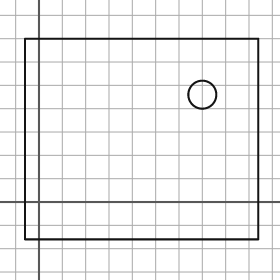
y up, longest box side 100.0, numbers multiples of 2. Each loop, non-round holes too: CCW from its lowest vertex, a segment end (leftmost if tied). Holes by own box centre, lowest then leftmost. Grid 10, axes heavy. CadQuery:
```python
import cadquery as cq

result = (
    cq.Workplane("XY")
    .moveTo(-6.0, -16.0)
    .lineTo(94.0, -16.0)
    .lineTo(94.0, 70.0)
    .lineTo(-6.0, 70.0)
    .close()
    .moveTo(70.0, 46.0)
    .circle(6.0)
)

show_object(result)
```